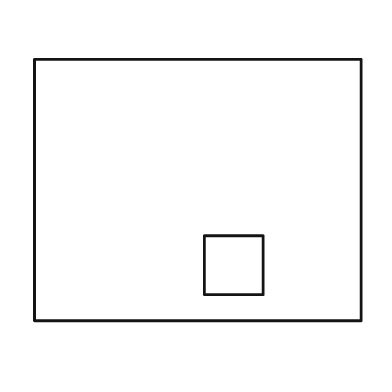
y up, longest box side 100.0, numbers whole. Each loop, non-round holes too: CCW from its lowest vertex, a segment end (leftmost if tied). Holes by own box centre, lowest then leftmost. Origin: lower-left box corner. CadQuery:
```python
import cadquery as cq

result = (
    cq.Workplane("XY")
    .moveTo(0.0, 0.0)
    .lineTo(100.0, 0.0)
    .lineTo(100.0, 80.0)
    .lineTo(0.0, 80.0)
    .close()
    .moveTo(52.0, 8.0)
    .lineTo(70.0, 8.0)
    .lineTo(70.0, 26.0)
    .lineTo(52.0, 26.0)
    .close()
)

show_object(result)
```